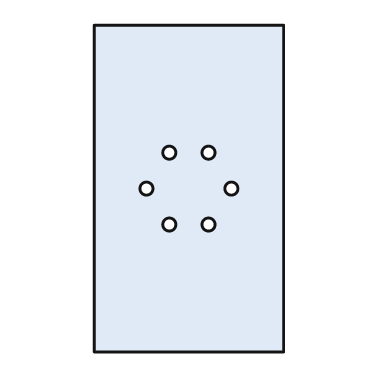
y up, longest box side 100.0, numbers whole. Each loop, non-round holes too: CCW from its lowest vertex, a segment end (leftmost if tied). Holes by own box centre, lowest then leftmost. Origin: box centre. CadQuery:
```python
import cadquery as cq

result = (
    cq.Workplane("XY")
    .moveTo(-29.0, -50.0)
    .lineTo(29.0, -50.0)
    .lineTo(29.0, 50.0)
    .lineTo(-29.0, 50.0)
    .close()
    .moveTo(-6.0, -11.0)
    .circle(2.0)
    .moveTo(6.0, -11.0)
    .circle(2.0)
    .moveTo(-13.0, 0.0)
    .circle(2.0)
    .moveTo(13.0, 0.0)
    .circle(2.0)
    .moveTo(-6.0, 11.0)
    .circle(2.0)
    .moveTo(6.0, 11.0)
    .circle(2.0)
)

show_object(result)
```